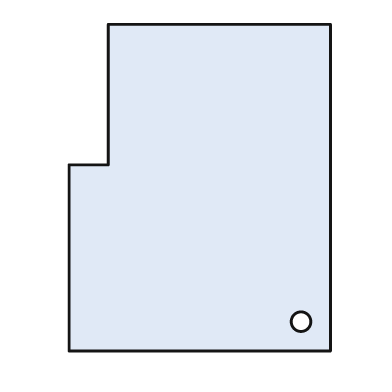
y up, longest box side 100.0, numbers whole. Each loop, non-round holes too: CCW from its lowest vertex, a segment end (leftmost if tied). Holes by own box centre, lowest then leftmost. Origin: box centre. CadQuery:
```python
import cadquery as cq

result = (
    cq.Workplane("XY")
    .moveTo(-40.0, -50.0)
    .lineTo(40.0, -50.0)
    .lineTo(40.0, 50.0)
    .lineTo(-28.0, 50.0)
    .lineTo(-28.0, 7.0)
    .lineTo(-40.0, 7.0)
    .close()
    .moveTo(31.0, -41.0)
    .circle(3.0)
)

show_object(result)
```